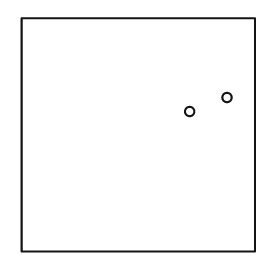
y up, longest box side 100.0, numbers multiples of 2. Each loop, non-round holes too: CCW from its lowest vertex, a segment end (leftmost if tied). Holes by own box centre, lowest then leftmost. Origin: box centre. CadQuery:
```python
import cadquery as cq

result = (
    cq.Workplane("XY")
    .moveTo(-50.0, -50.0)
    .lineTo(50.0, -50.0)
    .lineTo(50.0, 50.0)
    .lineTo(-50.0, 50.0)
    .close()
    .moveTo(22.0, 10.0)
    .circle(2.0)
    .moveTo(38.0, 16.0)
    .circle(2.0)
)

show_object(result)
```